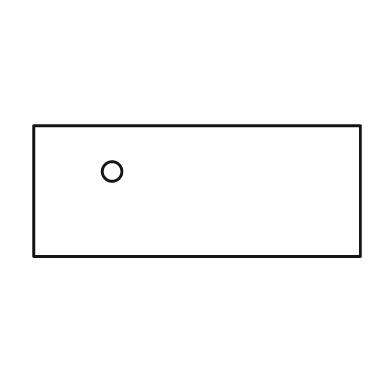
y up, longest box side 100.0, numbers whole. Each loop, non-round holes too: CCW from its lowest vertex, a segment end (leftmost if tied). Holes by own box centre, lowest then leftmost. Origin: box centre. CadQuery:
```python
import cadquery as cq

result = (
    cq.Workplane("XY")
    .moveTo(-50.0, -20.0)
    .lineTo(50.0, -20.0)
    .lineTo(50.0, 20.0)
    .lineTo(-50.0, 20.0)
    .close()
    .moveTo(-26.0, 6.0)
    .circle(3.0)
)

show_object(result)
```